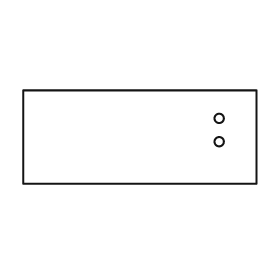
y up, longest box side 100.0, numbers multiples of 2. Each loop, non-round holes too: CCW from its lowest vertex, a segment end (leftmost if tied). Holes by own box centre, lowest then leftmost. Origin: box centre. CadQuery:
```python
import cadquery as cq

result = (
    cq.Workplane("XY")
    .moveTo(-50.0, -20.0)
    .lineTo(50.0, -20.0)
    .lineTo(50.0, 20.0)
    .lineTo(-50.0, 20.0)
    .close()
    .moveTo(34.0, -2.0)
    .circle(2.0)
    .moveTo(34.0, 8.0)
    .circle(2.0)
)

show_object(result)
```